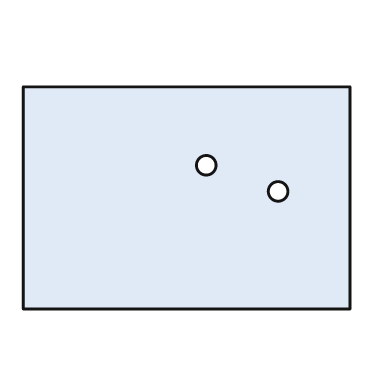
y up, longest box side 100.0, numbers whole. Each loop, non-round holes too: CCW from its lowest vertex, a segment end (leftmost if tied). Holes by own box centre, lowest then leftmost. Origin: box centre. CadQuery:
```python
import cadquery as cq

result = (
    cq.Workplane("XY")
    .moveTo(-50.0, -34.0)
    .lineTo(50.0, -34.0)
    .lineTo(50.0, 34.0)
    .lineTo(-50.0, 34.0)
    .close()
    .moveTo(28.0, 2.0)
    .circle(3.0)
    .moveTo(6.0, 10.0)
    .circle(3.0)
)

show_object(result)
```